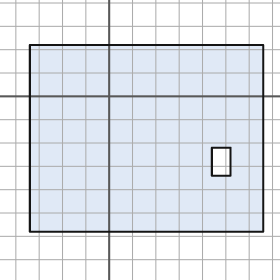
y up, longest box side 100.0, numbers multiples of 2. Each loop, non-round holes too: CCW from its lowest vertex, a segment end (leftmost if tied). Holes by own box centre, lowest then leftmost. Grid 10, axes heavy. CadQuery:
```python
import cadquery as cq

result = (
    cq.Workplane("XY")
    .moveTo(-34.0, -58.0)
    .lineTo(66.0, -58.0)
    .lineTo(66.0, 22.0)
    .lineTo(-34.0, 22.0)
    .close()
    .moveTo(44.0, -34.0)
    .lineTo(52.0, -34.0)
    .lineTo(52.0, -22.0)
    .lineTo(44.0, -22.0)
    .close()
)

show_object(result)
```